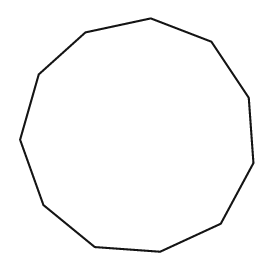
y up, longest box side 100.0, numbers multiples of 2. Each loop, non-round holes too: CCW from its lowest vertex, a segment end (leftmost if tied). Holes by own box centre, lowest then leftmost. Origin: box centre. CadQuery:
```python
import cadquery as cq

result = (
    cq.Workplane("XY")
    .moveTo(10.0, -50.0)
    .lineTo(36.0, -38.0)
    .lineTo(50.0, -12.0)
    .lineTo(48.0, 16.0)
    .lineTo(32.0, 40.0)
    .lineTo(6.0, 50.0)
    .lineTo(-22.0, 44.0)
    .lineTo(-42.0, 26.0)
    .lineTo(-50.0, -2.0)
    .lineTo(-40.0, -30.0)
    .lineTo(-18.0, -48.0)
    .close()
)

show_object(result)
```